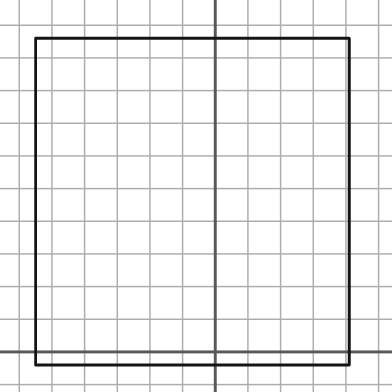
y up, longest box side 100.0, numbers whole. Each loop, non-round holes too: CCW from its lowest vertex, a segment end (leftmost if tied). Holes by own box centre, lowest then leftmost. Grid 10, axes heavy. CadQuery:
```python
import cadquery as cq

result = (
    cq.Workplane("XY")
    .moveTo(-55.0, -4.0)
    .lineTo(41.0, -4.0)
    .lineTo(41.0, 96.0)
    .lineTo(-55.0, 96.0)
    .close()
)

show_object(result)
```